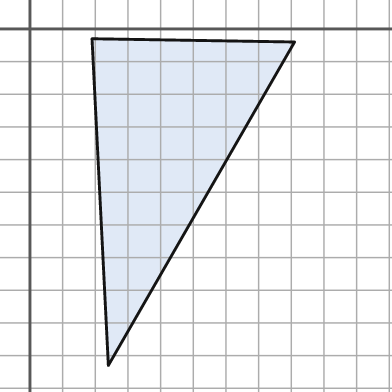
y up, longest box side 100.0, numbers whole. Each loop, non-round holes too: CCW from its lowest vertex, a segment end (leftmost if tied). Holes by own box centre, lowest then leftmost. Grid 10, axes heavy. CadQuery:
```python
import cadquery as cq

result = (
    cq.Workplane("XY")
    .moveTo(24.0, -103.0)
    .lineTo(81.0, -4.0)
    .lineTo(19.0, -3.0)
    .close()
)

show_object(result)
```